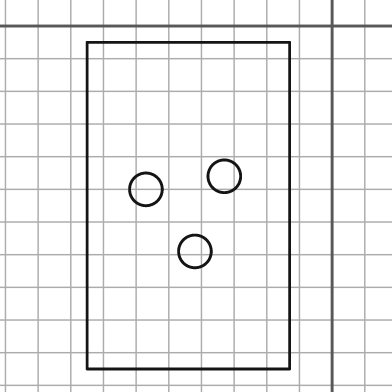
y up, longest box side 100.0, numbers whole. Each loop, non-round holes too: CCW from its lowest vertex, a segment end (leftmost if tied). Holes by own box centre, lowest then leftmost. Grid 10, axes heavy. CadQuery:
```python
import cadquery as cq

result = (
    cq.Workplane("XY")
    .moveTo(-75.0, -105.0)
    .lineTo(-13.0, -105.0)
    .lineTo(-13.0, -5.0)
    .lineTo(-75.0, -5.0)
    .close()
    .moveTo(-42.0, -69.0)
    .circle(5.0)
    .moveTo(-57.0, -50.0)
    .circle(5.0)
    .moveTo(-33.0, -46.0)
    .circle(5.0)
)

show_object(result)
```